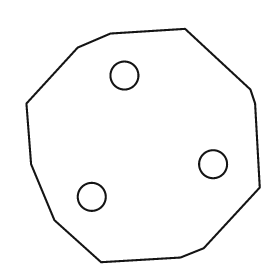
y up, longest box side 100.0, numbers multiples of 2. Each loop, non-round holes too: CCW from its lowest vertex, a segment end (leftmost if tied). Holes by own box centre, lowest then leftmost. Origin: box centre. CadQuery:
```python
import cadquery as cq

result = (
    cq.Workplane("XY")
    .moveTo(-18.0, -50.0)
    .lineTo(16.0, -48.0)
    .lineTo(26.0, -44.0)
    .lineTo(50.0, -18.0)
    .lineTo(48.0, 18.0)
    .lineTo(46.0, 24.0)
    .lineTo(18.0, 50.0)
    .lineTo(-14.0, 48.0)
    .lineTo(-28.0, 42.0)
    .lineTo(-50.0, 18.0)
    .lineTo(-48.0, -8.0)
    .lineTo(-38.0, -32.0)
    .close()
    .moveTo(-22.0, -22.0)
    .circle(6.0)
    .moveTo(30.0, -8.0)
    .circle(6.0)
    .moveTo(-8.0, 30.0)
    .circle(6.0)
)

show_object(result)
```